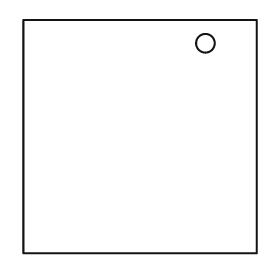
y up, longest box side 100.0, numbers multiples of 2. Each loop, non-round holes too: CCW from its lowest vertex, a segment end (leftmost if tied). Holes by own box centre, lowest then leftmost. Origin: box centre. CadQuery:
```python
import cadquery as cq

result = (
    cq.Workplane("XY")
    .moveTo(-50.0, -50.0)
    .lineTo(50.0, -50.0)
    .lineTo(50.0, 50.0)
    .lineTo(-50.0, 50.0)
    .close()
    .moveTo(28.0, 40.0)
    .circle(4.0)
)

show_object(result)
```